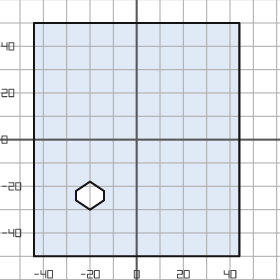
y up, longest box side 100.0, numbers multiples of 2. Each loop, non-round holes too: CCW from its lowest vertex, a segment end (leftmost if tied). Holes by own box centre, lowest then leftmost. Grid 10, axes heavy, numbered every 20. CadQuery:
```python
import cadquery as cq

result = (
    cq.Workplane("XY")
    .moveTo(-44.0, -50.0)
    .lineTo(44.0, -50.0)
    .lineTo(44.0, 50.0)
    .lineTo(-44.0, 50.0)
    .close()
    .moveTo(-20.0, -30.0)
    .lineTo(-14.0, -26.0)
    .lineTo(-14.0, -22.0)
    .lineTo(-20.0, -18.0)
    .lineTo(-26.0, -22.0)
    .lineTo(-26.0, -26.0)
    .close()
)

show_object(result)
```